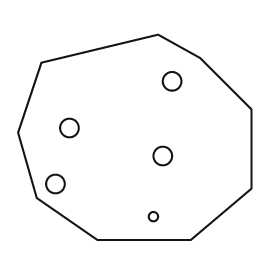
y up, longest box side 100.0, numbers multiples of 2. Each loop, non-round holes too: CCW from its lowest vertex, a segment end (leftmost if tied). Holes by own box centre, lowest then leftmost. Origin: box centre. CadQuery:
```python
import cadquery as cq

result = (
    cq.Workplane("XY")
    .moveTo(-16.0, -44.0)
    .lineTo(24.0, -44.0)
    .lineTo(50.0, -22.0)
    .lineTo(50.0, 12.0)
    .lineTo(28.0, 34.0)
    .lineTo(10.0, 44.0)
    .lineTo(-40.0, 32.0)
    .lineTo(-50.0, 2.0)
    .lineTo(-42.0, -26.0)
    .close()
    .moveTo(8.0, -34.0)
    .circle(2.0)
    .moveTo(-34.0, -20.0)
    .circle(4.0)
    .moveTo(12.0, -8.0)
    .circle(4.0)
    .moveTo(-28.0, 4.0)
    .circle(4.0)
    .moveTo(16.0, 24.0)
    .circle(4.0)
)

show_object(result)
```